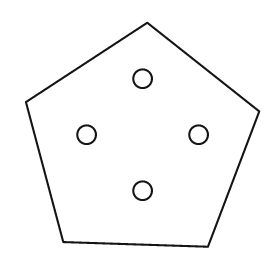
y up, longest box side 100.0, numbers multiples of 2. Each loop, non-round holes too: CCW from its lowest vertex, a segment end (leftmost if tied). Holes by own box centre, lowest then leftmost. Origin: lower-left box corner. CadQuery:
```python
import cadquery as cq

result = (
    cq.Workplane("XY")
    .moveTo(78.0, 0.0)
    .lineTo(100.0, 58.0)
    .lineTo(52.0, 96.0)
    .lineTo(0.0, 62.0)
    .lineTo(16.0, 2.0)
    .close()
    .moveTo(50.0, 24.0)
    .circle(4.0)
    .moveTo(26.0, 48.0)
    .circle(4.0)
    .moveTo(74.0, 48.0)
    .circle(4.0)
    .moveTo(50.0, 72.0)
    .circle(4.0)
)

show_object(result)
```